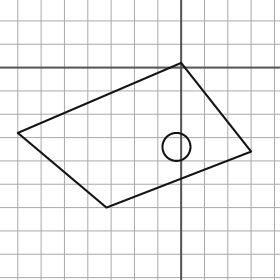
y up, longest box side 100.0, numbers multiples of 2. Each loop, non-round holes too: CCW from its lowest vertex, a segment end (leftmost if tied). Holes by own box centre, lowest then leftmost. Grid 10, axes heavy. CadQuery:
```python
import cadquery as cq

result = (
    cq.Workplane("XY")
    .moveTo(-32.0, -60.0)
    .lineTo(30.0, -36.0)
    .lineTo(0.0, 2.0)
    .lineTo(-70.0, -28.0)
    .close()
    .moveTo(-2.0, -34.0)
    .circle(6.0)
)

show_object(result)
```